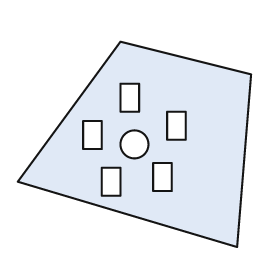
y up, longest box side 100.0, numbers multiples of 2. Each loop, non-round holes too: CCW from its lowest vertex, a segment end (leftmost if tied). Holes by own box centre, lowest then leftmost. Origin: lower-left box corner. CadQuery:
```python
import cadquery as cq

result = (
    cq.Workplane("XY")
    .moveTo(94.0, 0.0)
    .lineTo(100.0, 74.0)
    .lineTo(44.0, 88.0)
    .lineTo(0.0, 28.0)
    .close()
    .moveTo(36.0, 22.0)
    .lineTo(44.0, 22.0)
    .lineTo(44.0, 34.0)
    .lineTo(36.0, 34.0)
    .close()
    .moveTo(58.0, 24.0)
    .lineTo(66.0, 24.0)
    .lineTo(66.0, 36.0)
    .lineTo(58.0, 36.0)
    .close()
    .moveTo(50.0, 44.0)
    .circle(6.0)
    .moveTo(28.0, 42.0)
    .lineTo(36.0, 42.0)
    .lineTo(36.0, 54.0)
    .lineTo(28.0, 54.0)
    .close()
    .moveTo(64.0, 46.0)
    .lineTo(72.0, 46.0)
    .lineTo(72.0, 58.0)
    .lineTo(64.0, 58.0)
    .close()
    .moveTo(44.0, 58.0)
    .lineTo(52.0, 58.0)
    .lineTo(52.0, 70.0)
    .lineTo(44.0, 70.0)
    .close()
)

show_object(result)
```